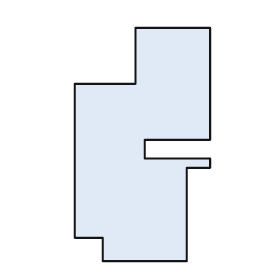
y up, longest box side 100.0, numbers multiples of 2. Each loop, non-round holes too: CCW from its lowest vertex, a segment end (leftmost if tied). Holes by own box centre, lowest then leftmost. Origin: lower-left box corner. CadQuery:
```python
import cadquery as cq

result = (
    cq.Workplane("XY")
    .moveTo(12.0, 0.0)
    .lineTo(48.0, 0.0)
    .lineTo(48.0, 40.0)
    .lineTo(58.0, 40.0)
    .lineTo(58.0, 44.0)
    .lineTo(30.0, 44.0)
    .lineTo(30.0, 52.0)
    .lineTo(58.0, 52.0)
    .lineTo(58.0, 100.0)
    .lineTo(26.0, 100.0)
    .lineTo(26.0, 76.0)
    .lineTo(0.0, 76.0)
    .lineTo(0.0, 10.0)
    .lineTo(12.0, 10.0)
    .close()
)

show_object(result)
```